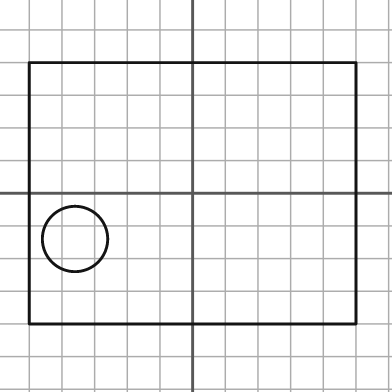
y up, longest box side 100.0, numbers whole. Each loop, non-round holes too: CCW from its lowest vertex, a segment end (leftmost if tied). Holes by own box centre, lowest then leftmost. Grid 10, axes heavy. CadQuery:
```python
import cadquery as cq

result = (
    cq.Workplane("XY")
    .moveTo(-50.0, -40.0)
    .lineTo(50.0, -40.0)
    .lineTo(50.0, 40.0)
    .lineTo(-50.0, 40.0)
    .close()
    .moveTo(-36.0, -14.0)
    .circle(10.0)
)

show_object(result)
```